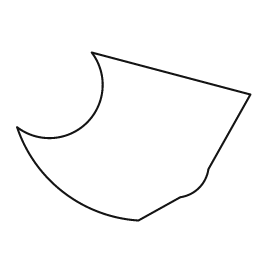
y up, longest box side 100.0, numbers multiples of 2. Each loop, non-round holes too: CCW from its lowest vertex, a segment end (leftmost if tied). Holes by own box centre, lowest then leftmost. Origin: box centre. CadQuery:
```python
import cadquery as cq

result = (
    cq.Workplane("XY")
    .moveTo(2.0, -36.0)
    .lineTo(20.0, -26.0)
    .threePointArc((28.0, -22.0), (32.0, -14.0))
    .lineTo(50.0, 18.0)
    .lineTo(-18.0, 36.0)
    .threePointArc((-20.0, 6.0), (-50.0, 4.0))
    .threePointArc((-30.0, -24.0), (2.0, -36.0))
    .close()
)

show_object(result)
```